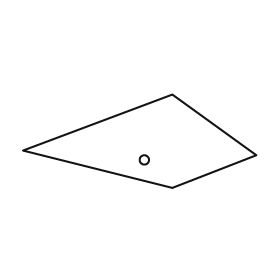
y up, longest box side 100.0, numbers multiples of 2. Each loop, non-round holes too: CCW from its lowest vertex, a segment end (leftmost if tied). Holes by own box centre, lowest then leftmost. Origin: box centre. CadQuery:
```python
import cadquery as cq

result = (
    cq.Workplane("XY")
    .moveTo(14.0, -20.0)
    .lineTo(50.0, -6.0)
    .lineTo(14.0, 20.0)
    .lineTo(-50.0, -4.0)
    .close()
    .moveTo(2.0, -8.0)
    .circle(2.0)
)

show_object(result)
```